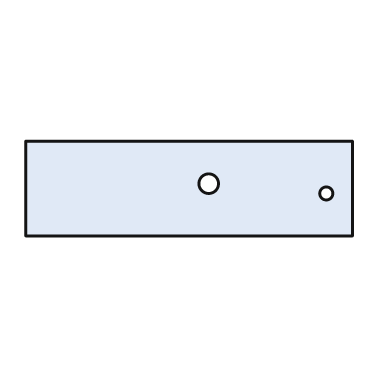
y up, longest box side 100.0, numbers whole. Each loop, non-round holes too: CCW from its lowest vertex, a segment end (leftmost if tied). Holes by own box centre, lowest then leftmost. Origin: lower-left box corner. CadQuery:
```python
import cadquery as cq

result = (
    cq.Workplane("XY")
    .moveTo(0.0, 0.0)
    .lineTo(100.0, 0.0)
    .lineTo(100.0, 29.0)
    .lineTo(0.0, 29.0)
    .close()
    .moveTo(92.0, 13.0)
    .circle(2.0)
    .moveTo(56.0, 16.0)
    .circle(3.0)
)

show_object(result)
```